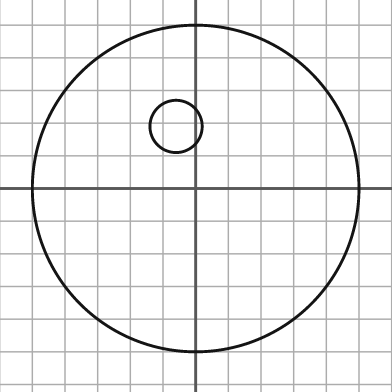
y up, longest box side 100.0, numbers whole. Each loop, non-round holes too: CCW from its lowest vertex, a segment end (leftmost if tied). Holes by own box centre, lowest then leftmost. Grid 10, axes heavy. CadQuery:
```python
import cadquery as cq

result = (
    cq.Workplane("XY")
    .moveTo(0.0, 0.0)
    .circle(50.0)
    .moveTo(-6.0, 19.0)
    .circle(8.0)
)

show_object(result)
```